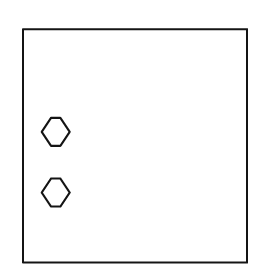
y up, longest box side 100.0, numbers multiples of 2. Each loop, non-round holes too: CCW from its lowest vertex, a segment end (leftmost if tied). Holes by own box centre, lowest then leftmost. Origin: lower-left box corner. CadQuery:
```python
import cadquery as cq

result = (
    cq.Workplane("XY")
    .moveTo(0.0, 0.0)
    .lineTo(96.0, 0.0)
    .lineTo(96.0, 100.0)
    .lineTo(0.0, 100.0)
    .close()
    .moveTo(12.0, 24.0)
    .lineTo(16.0, 24.0)
    .lineTo(20.0, 30.0)
    .lineTo(16.0, 36.0)
    .lineTo(12.0, 36.0)
    .lineTo(8.0, 30.0)
    .close()
    .moveTo(12.0, 50.0)
    .lineTo(16.0, 50.0)
    .lineTo(20.0, 56.0)
    .lineTo(16.0, 62.0)
    .lineTo(12.0, 62.0)
    .lineTo(8.0, 56.0)
    .close()
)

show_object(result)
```